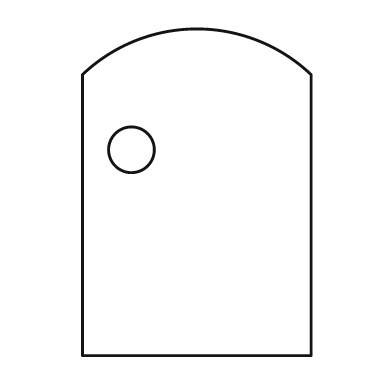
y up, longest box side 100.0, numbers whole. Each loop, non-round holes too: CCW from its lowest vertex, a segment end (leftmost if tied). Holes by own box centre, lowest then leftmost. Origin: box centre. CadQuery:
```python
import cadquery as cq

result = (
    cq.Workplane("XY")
    .moveTo(-35.0, -50.0)
    .lineTo(35.0, -50.0)
    .lineTo(35.0, 36.0)
    .threePointArc((0.0, 50.0), (-35.0, 36.0))
    .close()
    .moveTo(-20.0, 13.0)
    .circle(7.0)
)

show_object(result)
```